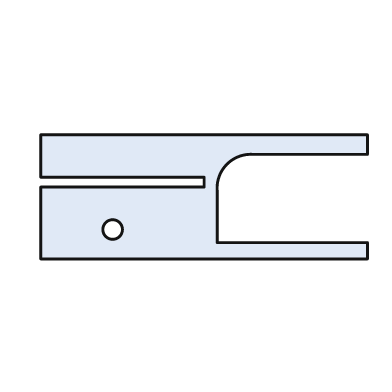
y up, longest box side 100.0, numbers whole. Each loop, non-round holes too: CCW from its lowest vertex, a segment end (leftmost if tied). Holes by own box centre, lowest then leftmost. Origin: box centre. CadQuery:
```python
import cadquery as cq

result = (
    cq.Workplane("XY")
    .moveTo(-50.0, -19.0)
    .lineTo(50.0, -19.0)
    .lineTo(50.0, -14.0)
    .lineTo(4.0, -14.0)
    .lineTo(4.0, 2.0)
    .threePointArc((7.0, 10.0), (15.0, 13.0))
    .lineTo(50.0, 13.0)
    .lineTo(50.0, 19.0)
    .lineTo(-50.0, 19.0)
    .lineTo(-50.0, 6.0)
    .lineTo(0.0, 6.0)
    .lineTo(0.0, 3.0)
    .lineTo(-50.0, 3.0)
    .close()
    .moveTo(-28.0, -10.0)
    .circle(3.0)
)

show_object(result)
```